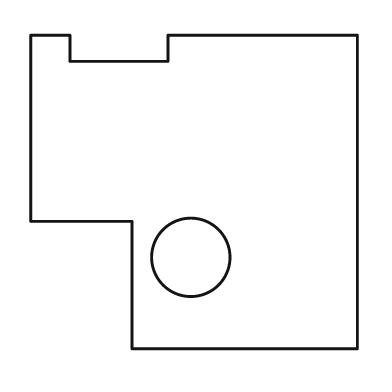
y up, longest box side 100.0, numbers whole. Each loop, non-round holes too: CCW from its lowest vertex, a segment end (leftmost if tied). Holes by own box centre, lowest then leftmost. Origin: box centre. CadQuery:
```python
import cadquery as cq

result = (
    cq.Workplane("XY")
    .moveTo(-19.0, -48.0)
    .lineTo(50.0, -48.0)
    .lineTo(50.0, 48.0)
    .lineTo(-8.0, 48.0)
    .lineTo(-8.0, 40.0)
    .lineTo(-38.0, 40.0)
    .lineTo(-38.0, 48.0)
    .lineTo(-50.0, 48.0)
    .lineTo(-50.0, -9.0)
    .lineTo(-19.0, -9.0)
    .close()
    .moveTo(-1.0, -20.0)
    .circle(12.0)
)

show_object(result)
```